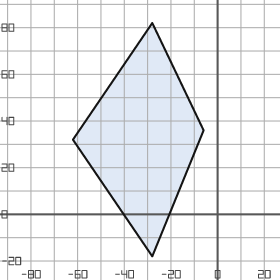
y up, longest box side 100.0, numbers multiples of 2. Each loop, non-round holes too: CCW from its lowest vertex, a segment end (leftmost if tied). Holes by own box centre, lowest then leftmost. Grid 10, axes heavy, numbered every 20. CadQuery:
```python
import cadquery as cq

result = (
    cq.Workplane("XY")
    .moveTo(-28.0, -18.0)
    .lineTo(-6.0, 36.0)
    .lineTo(-28.0, 82.0)
    .lineTo(-62.0, 32.0)
    .close()
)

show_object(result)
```